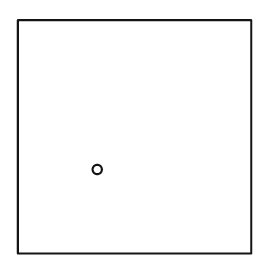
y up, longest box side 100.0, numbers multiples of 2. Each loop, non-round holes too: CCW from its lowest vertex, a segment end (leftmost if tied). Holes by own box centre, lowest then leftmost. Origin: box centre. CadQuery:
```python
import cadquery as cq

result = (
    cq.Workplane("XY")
    .moveTo(-50.0, -50.0)
    .lineTo(50.0, -50.0)
    .lineTo(50.0, 50.0)
    .lineTo(-50.0, 50.0)
    .close()
    .moveTo(-16.0, -14.0)
    .circle(2.0)
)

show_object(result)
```